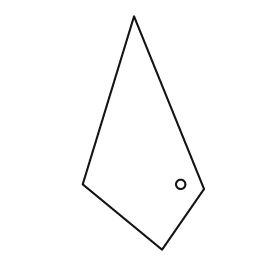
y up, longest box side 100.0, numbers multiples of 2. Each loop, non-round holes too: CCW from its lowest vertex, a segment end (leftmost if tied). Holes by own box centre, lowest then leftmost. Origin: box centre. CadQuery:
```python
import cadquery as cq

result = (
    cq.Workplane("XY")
    .moveTo(8.0, -50.0)
    .lineTo(26.0, -24.0)
    .lineTo(-4.0, 50.0)
    .lineTo(-26.0, -22.0)
    .close()
    .moveTo(16.0, -22.0)
    .circle(2.0)
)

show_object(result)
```